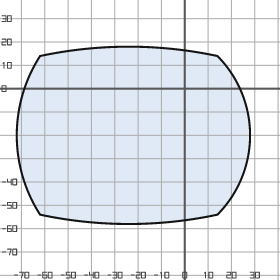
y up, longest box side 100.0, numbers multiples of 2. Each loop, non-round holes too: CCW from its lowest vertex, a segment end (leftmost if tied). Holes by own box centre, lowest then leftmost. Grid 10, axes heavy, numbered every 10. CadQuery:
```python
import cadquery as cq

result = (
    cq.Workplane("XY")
    .moveTo(-62.0, -54.0)
    .threePointArc((-24.0, -58.0), (14.0, -54.0))
    .threePointArc((28.0, -20.0), (14.0, 14.0))
    .threePointArc((-24.0, 18.0), (-62.0, 14.0))
    .threePointArc((-72.0, -20.0), (-62.0, -54.0))
    .close()
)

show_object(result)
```